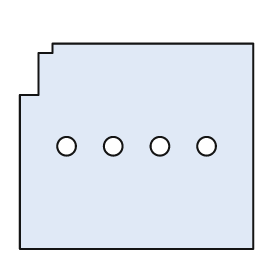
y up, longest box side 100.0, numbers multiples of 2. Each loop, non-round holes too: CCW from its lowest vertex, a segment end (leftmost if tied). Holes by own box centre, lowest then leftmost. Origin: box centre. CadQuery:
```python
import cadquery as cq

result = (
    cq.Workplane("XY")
    .moveTo(-50.0, -44.0)
    .lineTo(50.0, -44.0)
    .lineTo(50.0, 44.0)
    .lineTo(-36.0, 44.0)
    .lineTo(-36.0, 40.0)
    .lineTo(-42.0, 40.0)
    .lineTo(-42.0, 22.0)
    .lineTo(-50.0, 22.0)
    .close()
    .moveTo(-30.0, 0.0)
    .circle(4.0)
    .moveTo(-10.0, 0.0)
    .circle(4.0)
    .moveTo(10.0, 0.0)
    .circle(4.0)
    .moveTo(30.0, 0.0)
    .circle(4.0)
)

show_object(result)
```